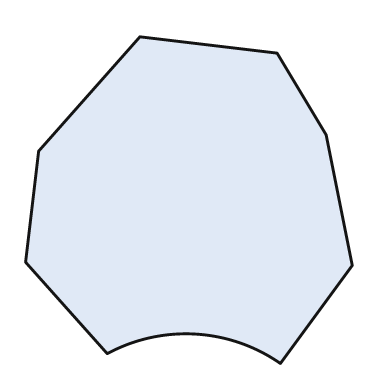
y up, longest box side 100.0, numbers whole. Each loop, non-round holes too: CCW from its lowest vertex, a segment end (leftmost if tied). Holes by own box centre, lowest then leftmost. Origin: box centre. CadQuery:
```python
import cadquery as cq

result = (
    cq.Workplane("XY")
    .moveTo(28.0, -50.0)
    .lineTo(50.0, -20.0)
    .lineTo(42.0, 20.0)
    .lineTo(27.0, 45.0)
    .lineTo(-15.0, 50.0)
    .lineTo(-46.0, 15.0)
    .lineTo(-50.0, -19.0)
    .lineTo(-25.0, -47.0)
    .threePointArc((2.0, -41.0), (28.0, -50.0))
    .close()
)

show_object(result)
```